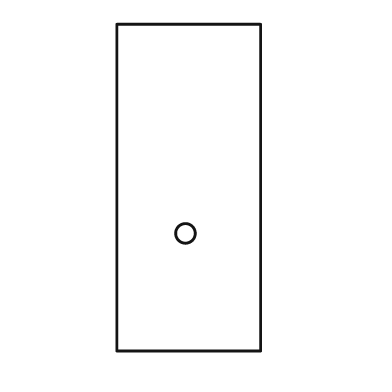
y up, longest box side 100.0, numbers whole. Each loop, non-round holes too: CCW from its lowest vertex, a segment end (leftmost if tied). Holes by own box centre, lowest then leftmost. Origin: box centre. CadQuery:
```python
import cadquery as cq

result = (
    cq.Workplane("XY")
    .moveTo(-22.0, -50.0)
    .lineTo(22.0, -50.0)
    .lineTo(22.0, 50.0)
    .lineTo(-22.0, 50.0)
    .close()
    .moveTo(-1.0, -14.0)
    .circle(3.0)
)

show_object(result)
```